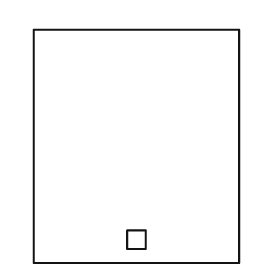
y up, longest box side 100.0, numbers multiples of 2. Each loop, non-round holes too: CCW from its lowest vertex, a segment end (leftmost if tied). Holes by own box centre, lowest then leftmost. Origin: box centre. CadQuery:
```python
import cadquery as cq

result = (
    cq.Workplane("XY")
    .moveTo(-44.0, -50.0)
    .lineTo(44.0, -50.0)
    .lineTo(44.0, 50.0)
    .lineTo(-44.0, 50.0)
    .close()
    .moveTo(-4.0, -44.0)
    .lineTo(4.0, -44.0)
    .lineTo(4.0, -36.0)
    .lineTo(-4.0, -36.0)
    .close()
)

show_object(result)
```